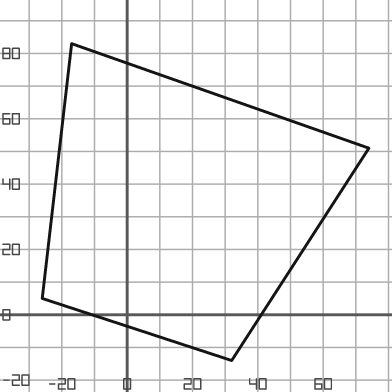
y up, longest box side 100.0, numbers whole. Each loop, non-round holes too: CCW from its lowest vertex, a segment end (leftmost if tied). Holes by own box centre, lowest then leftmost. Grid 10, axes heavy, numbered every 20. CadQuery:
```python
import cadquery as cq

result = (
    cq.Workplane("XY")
    .moveTo(32.0, -14.0)
    .lineTo(74.0, 51.0)
    .lineTo(-17.0, 83.0)
    .lineTo(-26.0, 5.0)
    .close()
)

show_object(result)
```